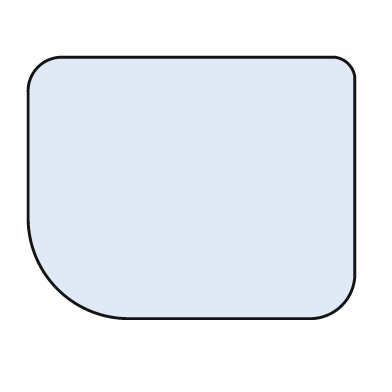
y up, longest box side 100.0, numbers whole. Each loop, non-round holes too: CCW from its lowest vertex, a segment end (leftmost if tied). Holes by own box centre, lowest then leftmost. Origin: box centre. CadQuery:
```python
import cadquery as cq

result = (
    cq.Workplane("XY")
    .moveTo(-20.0, -40.0)
    .lineTo(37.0, -40.0)
    .threePointArc((46.0, -36.0), (50.0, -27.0))
    .lineTo(50.0, 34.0)
    .threePointArc((48.0, 38.0), (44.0, 40.0))
    .lineTo(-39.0, 40.0)
    .threePointArc((-47.0, 37.0), (-50.0, 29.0))
    .lineTo(-50.0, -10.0)
    .threePointArc((-41.0, -31.0), (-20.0, -40.0))
    .close()
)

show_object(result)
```